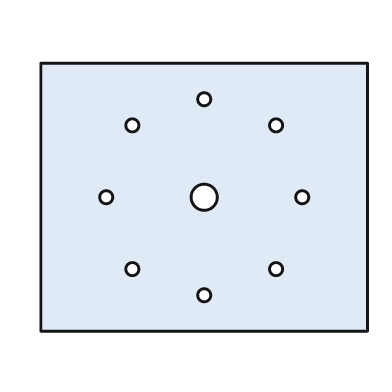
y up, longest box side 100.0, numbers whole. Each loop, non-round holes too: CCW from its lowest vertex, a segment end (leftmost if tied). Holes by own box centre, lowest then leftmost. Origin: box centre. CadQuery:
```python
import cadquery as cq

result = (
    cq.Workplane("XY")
    .moveTo(-50.0, -41.0)
    .lineTo(50.0, -41.0)
    .lineTo(50.0, 41.0)
    .lineTo(-50.0, 41.0)
    .close()
    .moveTo(0.0, -30.0)
    .circle(2.0)
    .moveTo(-22.0, -22.0)
    .circle(2.0)
    .moveTo(22.0, -22.0)
    .circle(2.0)
    .moveTo(-30.0, 0.0)
    .circle(2.0)
    .moveTo(0.0, 0.0)
    .circle(4.0)
    .moveTo(30.0, 0.0)
    .circle(2.0)
    .moveTo(-22.0, 22.0)
    .circle(2.0)
    .moveTo(22.0, 22.0)
    .circle(2.0)
    .moveTo(0.0, 30.0)
    .circle(2.0)
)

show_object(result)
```